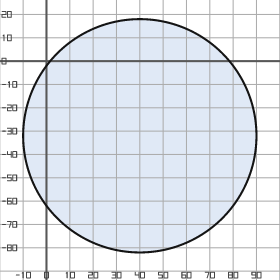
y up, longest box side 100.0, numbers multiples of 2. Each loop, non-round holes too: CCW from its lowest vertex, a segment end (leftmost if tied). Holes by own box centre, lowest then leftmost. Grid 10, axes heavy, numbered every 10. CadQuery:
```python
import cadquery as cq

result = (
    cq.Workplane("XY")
    .moveTo(40.0, -32.0)
    .circle(50.0)
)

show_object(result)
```